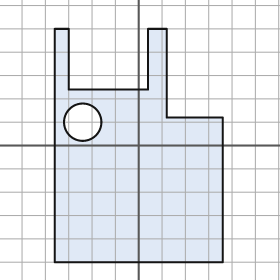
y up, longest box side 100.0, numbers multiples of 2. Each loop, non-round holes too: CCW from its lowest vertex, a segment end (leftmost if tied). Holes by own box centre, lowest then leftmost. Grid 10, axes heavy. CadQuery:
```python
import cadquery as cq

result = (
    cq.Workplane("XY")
    .moveTo(-36.0, -50.0)
    .lineTo(36.0, -50.0)
    .lineTo(36.0, 12.0)
    .lineTo(12.0, 12.0)
    .lineTo(12.0, 50.0)
    .lineTo(4.0, 50.0)
    .lineTo(4.0, 24.0)
    .lineTo(-30.0, 24.0)
    .lineTo(-30.0, 50.0)
    .lineTo(-36.0, 50.0)
    .close()
    .moveTo(-24.0, 10.0)
    .circle(8.0)
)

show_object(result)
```